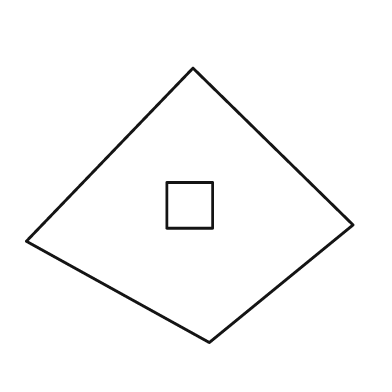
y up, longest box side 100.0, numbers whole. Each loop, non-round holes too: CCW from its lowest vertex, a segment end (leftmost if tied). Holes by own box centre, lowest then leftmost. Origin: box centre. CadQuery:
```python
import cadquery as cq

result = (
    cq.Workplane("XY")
    .moveTo(6.0, -42.0)
    .lineTo(50.0, -6.0)
    .lineTo(1.0, 42.0)
    .lineTo(-50.0, -11.0)
    .close()
    .moveTo(-7.0, -7.0)
    .lineTo(7.0, -7.0)
    .lineTo(7.0, 7.0)
    .lineTo(-7.0, 7.0)
    .close()
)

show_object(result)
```